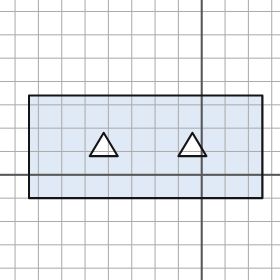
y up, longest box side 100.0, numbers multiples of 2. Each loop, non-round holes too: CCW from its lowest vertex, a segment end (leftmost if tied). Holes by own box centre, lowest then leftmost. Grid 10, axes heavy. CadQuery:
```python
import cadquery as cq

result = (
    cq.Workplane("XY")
    .moveTo(-74.0, -10.0)
    .lineTo(26.0, -10.0)
    .lineTo(26.0, 34.0)
    .lineTo(-74.0, 34.0)
    .close()
    .moveTo(-48.0, 8.0)
    .lineTo(-36.0, 8.0)
    .lineTo(-42.0, 18.0)
    .close()
    .moveTo(-10.0, 8.0)
    .lineTo(2.0, 8.0)
    .lineTo(-4.0, 18.0)
    .close()
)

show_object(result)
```